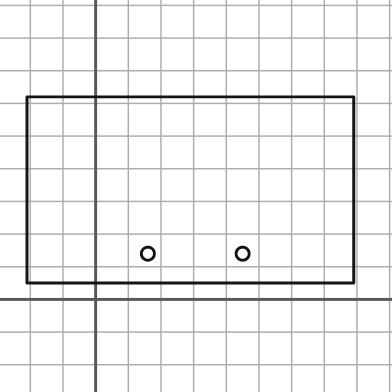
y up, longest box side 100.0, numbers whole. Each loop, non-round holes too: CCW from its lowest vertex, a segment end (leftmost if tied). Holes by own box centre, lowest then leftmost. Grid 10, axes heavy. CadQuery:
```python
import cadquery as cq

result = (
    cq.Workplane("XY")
    .moveTo(-21.0, 5.0)
    .lineTo(79.0, 5.0)
    .lineTo(79.0, 62.0)
    .lineTo(-21.0, 62.0)
    .close()
    .moveTo(16.0, 14.0)
    .circle(2.0)
    .moveTo(45.0, 14.0)
    .circle(2.0)
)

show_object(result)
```